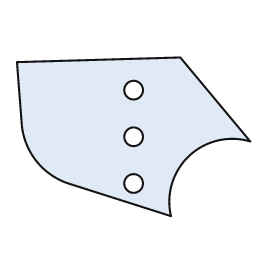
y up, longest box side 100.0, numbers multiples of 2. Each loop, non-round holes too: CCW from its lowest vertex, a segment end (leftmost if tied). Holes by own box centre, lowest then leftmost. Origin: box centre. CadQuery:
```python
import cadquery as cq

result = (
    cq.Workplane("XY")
    .moveTo(16.0, -34.0)
    .threePointArc((24.0, -8.0), (50.0, -2.0))
    .lineTo(20.0, 34.0)
    .lineTo(-50.0, 32.0)
    .lineTo(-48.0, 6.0)
    .threePointArc((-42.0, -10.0), (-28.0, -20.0))
    .close()
    .moveTo(0.0, -20.0)
    .circle(4.0)
    .moveTo(0.0, 0.0)
    .circle(4.0)
    .moveTo(0.0, 20.0)
    .circle(4.0)
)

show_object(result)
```